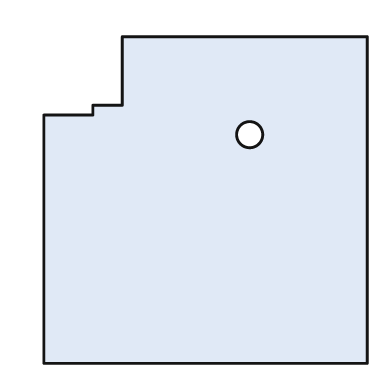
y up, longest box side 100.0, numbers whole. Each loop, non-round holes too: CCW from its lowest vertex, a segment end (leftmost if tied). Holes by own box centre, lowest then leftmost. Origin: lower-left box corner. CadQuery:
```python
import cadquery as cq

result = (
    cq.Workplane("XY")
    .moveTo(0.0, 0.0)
    .lineTo(99.0, 0.0)
    .lineTo(99.0, 100.0)
    .lineTo(24.0, 100.0)
    .lineTo(24.0, 79.0)
    .lineTo(15.0, 79.0)
    .lineTo(15.0, 76.0)
    .lineTo(0.0, 76.0)
    .close()
    .moveTo(63.0, 70.0)
    .circle(4.0)
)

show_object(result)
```